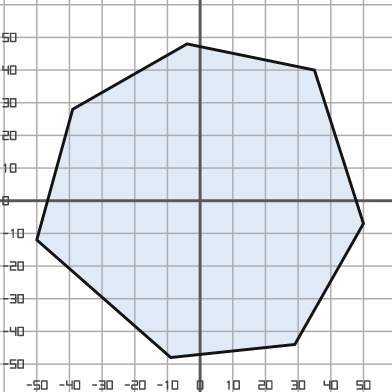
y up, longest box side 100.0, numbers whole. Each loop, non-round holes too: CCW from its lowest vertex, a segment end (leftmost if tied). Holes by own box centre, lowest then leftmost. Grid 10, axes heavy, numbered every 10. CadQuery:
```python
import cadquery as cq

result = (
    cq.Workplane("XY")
    .moveTo(-9.0, -48.0)
    .lineTo(29.0, -44.0)
    .lineTo(50.0, -7.0)
    .lineTo(35.0, 40.0)
    .lineTo(-4.0, 48.0)
    .lineTo(-39.0, 28.0)
    .lineTo(-50.0, -12.0)
    .close()
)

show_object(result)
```